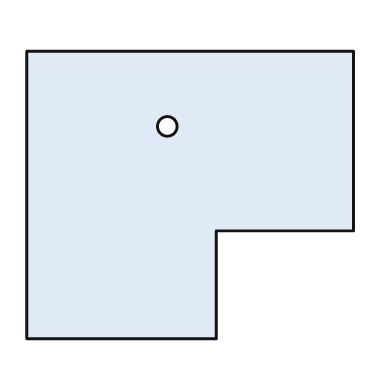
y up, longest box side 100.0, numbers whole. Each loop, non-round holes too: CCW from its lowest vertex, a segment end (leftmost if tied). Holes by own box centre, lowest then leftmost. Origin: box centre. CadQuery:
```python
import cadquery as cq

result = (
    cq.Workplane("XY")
    .moveTo(-50.0, -44.0)
    .lineTo(8.0, -44.0)
    .lineTo(8.0, -11.0)
    .lineTo(50.0, -11.0)
    .lineTo(50.0, 44.0)
    .lineTo(-50.0, 44.0)
    .close()
    .moveTo(-7.0, 21.0)
    .circle(3.0)
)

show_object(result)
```